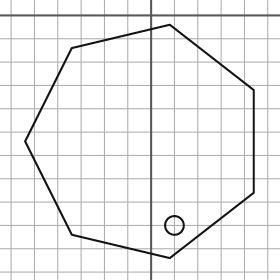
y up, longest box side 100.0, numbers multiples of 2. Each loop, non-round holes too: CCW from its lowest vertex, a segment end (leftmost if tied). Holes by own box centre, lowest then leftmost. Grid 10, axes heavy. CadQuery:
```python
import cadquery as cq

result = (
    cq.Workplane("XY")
    .moveTo(8.0, -104.0)
    .lineTo(44.0, -76.0)
    .lineTo(44.0, -32.0)
    .lineTo(8.0, -4.0)
    .lineTo(-34.0, -14.0)
    .lineTo(-54.0, -54.0)
    .lineTo(-34.0, -94.0)
    .close()
    .moveTo(10.0, -90.0)
    .circle(4.0)
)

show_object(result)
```